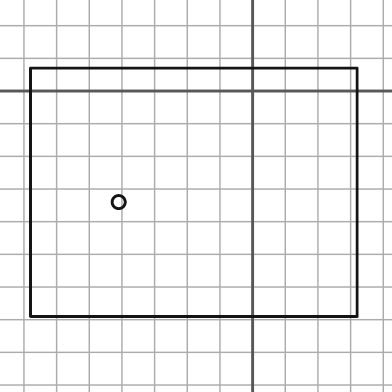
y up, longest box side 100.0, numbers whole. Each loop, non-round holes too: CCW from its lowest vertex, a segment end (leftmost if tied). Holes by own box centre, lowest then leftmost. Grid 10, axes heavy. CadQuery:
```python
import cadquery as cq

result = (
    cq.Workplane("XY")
    .moveTo(-68.0, -69.0)
    .lineTo(32.0, -69.0)
    .lineTo(32.0, 7.0)
    .lineTo(-68.0, 7.0)
    .close()
    .moveTo(-41.0, -34.0)
    .circle(2.0)
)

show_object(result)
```